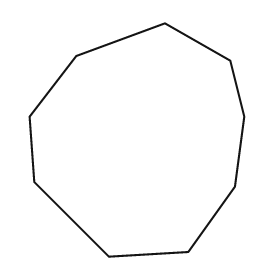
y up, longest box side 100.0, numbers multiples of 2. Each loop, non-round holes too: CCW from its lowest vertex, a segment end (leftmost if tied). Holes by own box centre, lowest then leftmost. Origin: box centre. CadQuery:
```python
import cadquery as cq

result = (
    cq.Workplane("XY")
    .moveTo(-12.0, -50.0)
    .lineTo(22.0, -48.0)
    .lineTo(42.0, -20.0)
    .lineTo(46.0, 10.0)
    .lineTo(40.0, 34.0)
    .lineTo(12.0, 50.0)
    .lineTo(-26.0, 36.0)
    .lineTo(-46.0, 10.0)
    .lineTo(-44.0, -18.0)
    .close()
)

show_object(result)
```